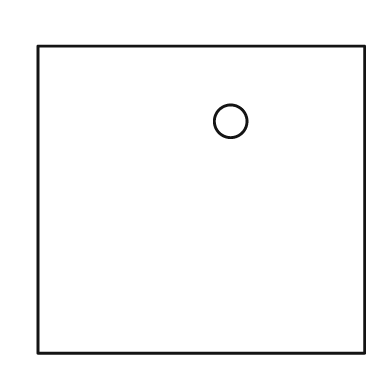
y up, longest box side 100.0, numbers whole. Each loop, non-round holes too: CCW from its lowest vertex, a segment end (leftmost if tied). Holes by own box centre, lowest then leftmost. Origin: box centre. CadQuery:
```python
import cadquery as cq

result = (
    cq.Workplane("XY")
    .moveTo(-50.0, -47.0)
    .lineTo(50.0, -47.0)
    .lineTo(50.0, 47.0)
    .lineTo(-50.0, 47.0)
    .close()
    .moveTo(9.0, 24.0)
    .circle(5.0)
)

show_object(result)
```